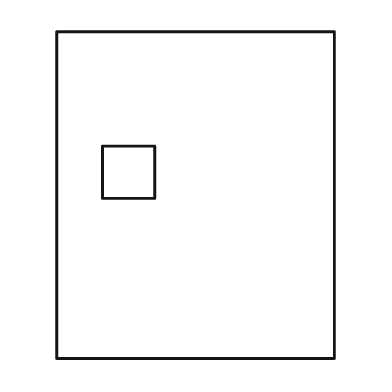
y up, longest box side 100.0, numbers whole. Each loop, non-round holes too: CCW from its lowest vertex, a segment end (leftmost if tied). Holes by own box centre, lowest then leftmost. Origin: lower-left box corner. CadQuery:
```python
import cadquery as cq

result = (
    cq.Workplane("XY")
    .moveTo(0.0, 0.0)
    .lineTo(85.0, 0.0)
    .lineTo(85.0, 100.0)
    .lineTo(0.0, 100.0)
    .close()
    .moveTo(14.0, 49.0)
    .lineTo(30.0, 49.0)
    .lineTo(30.0, 65.0)
    .lineTo(14.0, 65.0)
    .close()
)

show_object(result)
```